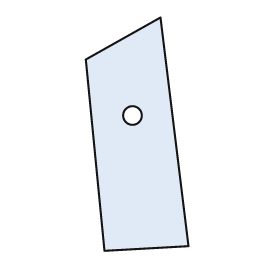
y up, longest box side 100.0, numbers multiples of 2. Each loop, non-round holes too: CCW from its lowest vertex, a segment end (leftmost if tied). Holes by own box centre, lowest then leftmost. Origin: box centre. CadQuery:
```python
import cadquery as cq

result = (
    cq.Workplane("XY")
    .moveTo(-14.0, -50.0)
    .lineTo(22.0, -48.0)
    .lineTo(10.0, 50.0)
    .lineTo(-22.0, 32.0)
    .close()
    .moveTo(-2.0, 8.0)
    .circle(4.0)
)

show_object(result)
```